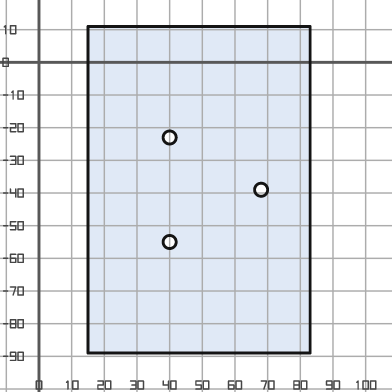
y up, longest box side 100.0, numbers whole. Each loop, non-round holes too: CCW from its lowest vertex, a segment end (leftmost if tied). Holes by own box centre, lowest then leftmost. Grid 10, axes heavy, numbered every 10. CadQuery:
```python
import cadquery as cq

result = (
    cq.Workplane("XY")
    .moveTo(15.0, -89.0)
    .lineTo(83.0, -89.0)
    .lineTo(83.0, 11.0)
    .lineTo(15.0, 11.0)
    .close()
    .moveTo(40.0, -55.0)
    .circle(2.0)
    .moveTo(68.0, -39.0)
    .circle(2.0)
    .moveTo(40.0, -23.0)
    .circle(2.0)
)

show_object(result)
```